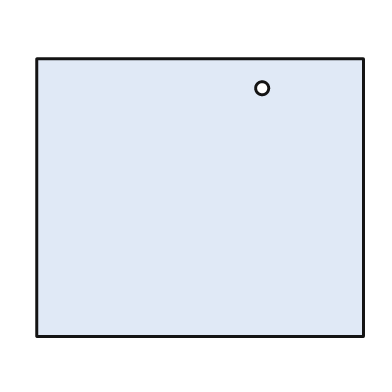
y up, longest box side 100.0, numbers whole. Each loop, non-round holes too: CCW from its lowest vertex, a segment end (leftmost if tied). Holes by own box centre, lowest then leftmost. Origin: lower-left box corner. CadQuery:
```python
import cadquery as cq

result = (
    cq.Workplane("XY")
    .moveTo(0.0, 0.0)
    .lineTo(100.0, 0.0)
    .lineTo(100.0, 85.0)
    .lineTo(0.0, 85.0)
    .close()
    .moveTo(69.0, 76.0)
    .circle(2.0)
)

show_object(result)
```